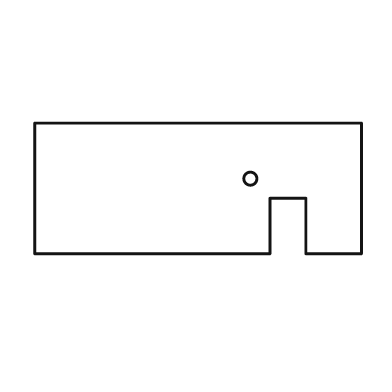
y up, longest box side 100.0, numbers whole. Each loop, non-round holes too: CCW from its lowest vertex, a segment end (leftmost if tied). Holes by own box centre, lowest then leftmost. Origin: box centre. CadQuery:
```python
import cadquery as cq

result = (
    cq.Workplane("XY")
    .moveTo(-50.0, -20.0)
    .lineTo(22.0, -20.0)
    .lineTo(22.0, -3.0)
    .lineTo(33.0, -3.0)
    .lineTo(33.0, -20.0)
    .lineTo(50.0, -20.0)
    .lineTo(50.0, 20.0)
    .lineTo(-50.0, 20.0)
    .close()
    .moveTo(16.0, 3.0)
    .circle(2.0)
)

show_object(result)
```